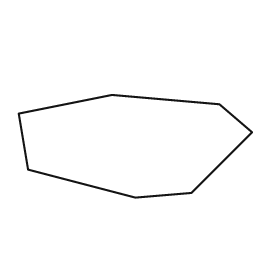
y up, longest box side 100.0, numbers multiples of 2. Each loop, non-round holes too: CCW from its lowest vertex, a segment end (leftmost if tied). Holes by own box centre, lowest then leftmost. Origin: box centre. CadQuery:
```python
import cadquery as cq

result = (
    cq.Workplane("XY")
    .moveTo(0.0, -22.0)
    .lineTo(24.0, -20.0)
    .lineTo(50.0, 6.0)
    .lineTo(36.0, 18.0)
    .lineTo(-10.0, 22.0)
    .lineTo(-50.0, 14.0)
    .lineTo(-46.0, -10.0)
    .close()
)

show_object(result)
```